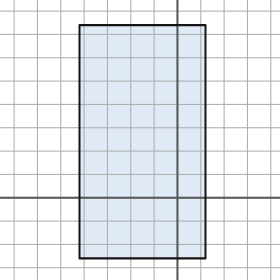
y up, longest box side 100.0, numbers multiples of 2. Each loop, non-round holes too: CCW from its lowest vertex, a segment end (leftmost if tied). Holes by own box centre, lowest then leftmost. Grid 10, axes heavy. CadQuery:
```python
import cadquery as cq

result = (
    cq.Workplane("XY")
    .moveTo(-42.0, -26.0)
    .lineTo(12.0, -26.0)
    .lineTo(12.0, 74.0)
    .lineTo(-42.0, 74.0)
    .close()
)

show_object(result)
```